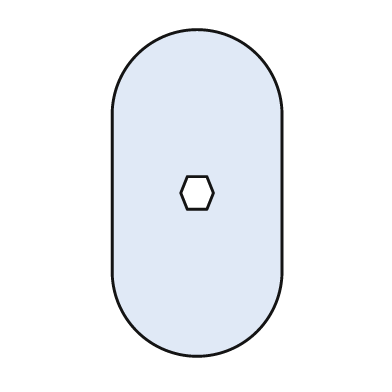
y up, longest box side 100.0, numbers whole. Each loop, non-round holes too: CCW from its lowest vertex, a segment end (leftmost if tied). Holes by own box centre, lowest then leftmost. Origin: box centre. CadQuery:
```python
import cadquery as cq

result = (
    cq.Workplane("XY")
    .moveTo(-26.0, -24.0)
    .threePointArc((0.0, -50.0), (26.0, -24.0))
    .lineTo(26.0, 24.0)
    .threePointArc((0.0, 50.0), (-26.0, 24.0))
    .close()
    .moveTo(-3.0, -5.0)
    .lineTo(3.0, -5.0)
    .lineTo(5.0, 0.0)
    .lineTo(3.0, 5.0)
    .lineTo(-3.0, 5.0)
    .lineTo(-5.0, 0.0)
    .close()
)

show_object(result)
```